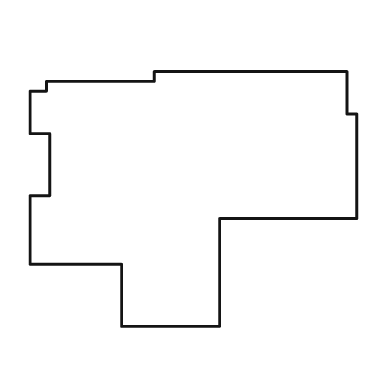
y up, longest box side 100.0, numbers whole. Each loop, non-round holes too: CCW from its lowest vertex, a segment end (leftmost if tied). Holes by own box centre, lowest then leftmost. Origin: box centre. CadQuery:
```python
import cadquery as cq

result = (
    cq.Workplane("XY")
    .moveTo(-22.0, -39.0)
    .lineTo(8.0, -39.0)
    .lineTo(8.0, -6.0)
    .lineTo(50.0, -6.0)
    .lineTo(50.0, 26.0)
    .lineTo(47.0, 26.0)
    .lineTo(47.0, 39.0)
    .lineTo(-12.0, 39.0)
    .lineTo(-12.0, 36.0)
    .lineTo(-45.0, 36.0)
    .lineTo(-45.0, 33.0)
    .lineTo(-50.0, 33.0)
    .lineTo(-50.0, 20.0)
    .lineTo(-44.0, 20.0)
    .lineTo(-44.0, 1.0)
    .lineTo(-50.0, 1.0)
    .lineTo(-50.0, -20.0)
    .lineTo(-22.0, -20.0)
    .close()
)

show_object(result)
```